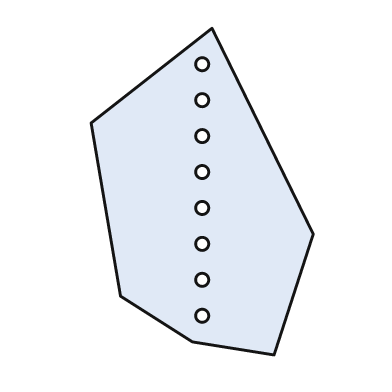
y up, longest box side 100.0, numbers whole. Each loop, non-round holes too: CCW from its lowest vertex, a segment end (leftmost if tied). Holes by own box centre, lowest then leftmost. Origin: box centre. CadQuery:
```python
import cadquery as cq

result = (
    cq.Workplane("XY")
    .moveTo(22.0, -50.0)
    .lineTo(34.0, -13.0)
    .lineTo(3.0, 50.0)
    .lineTo(-34.0, 21.0)
    .lineTo(-25.0, -32.0)
    .lineTo(-3.0, -46.0)
    .close()
    .moveTo(0.0, -38.0)
    .circle(2.0)
    .moveTo(0.0, -27.0)
    .circle(2.0)
    .moveTo(0.0, -16.0)
    .circle(2.0)
    .moveTo(0.0, -5.0)
    .circle(2.0)
    .moveTo(0.0, 6.0)
    .circle(2.0)
    .moveTo(0.0, 17.0)
    .circle(2.0)
    .moveTo(0.0, 28.0)
    .circle(2.0)
    .moveTo(0.0, 39.0)
    .circle(2.0)
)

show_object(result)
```